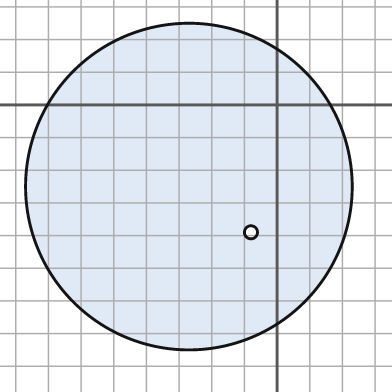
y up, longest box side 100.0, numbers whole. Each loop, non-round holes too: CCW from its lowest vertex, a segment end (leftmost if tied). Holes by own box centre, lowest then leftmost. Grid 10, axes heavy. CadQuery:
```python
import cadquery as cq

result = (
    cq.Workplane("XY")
    .moveTo(-27.0, -25.0)
    .circle(50.0)
    .moveTo(-8.0, -39.0)
    .circle(2.0)
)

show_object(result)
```